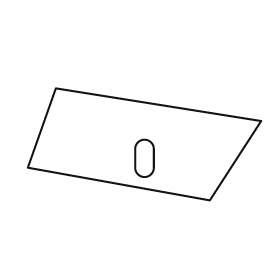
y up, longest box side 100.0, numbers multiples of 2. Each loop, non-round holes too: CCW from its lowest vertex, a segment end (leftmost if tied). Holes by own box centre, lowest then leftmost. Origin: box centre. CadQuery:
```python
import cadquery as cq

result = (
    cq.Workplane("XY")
    .moveTo(28.0, -24.0)
    .lineTo(50.0, 10.0)
    .lineTo(-38.0, 24.0)
    .lineTo(-50.0, -10.0)
    .close()
    .moveTo(-4.0, -10.0)
    .threePointArc((0.0, -14.0), (4.0, -10.0))
    .lineTo(4.0, -2.0)
    .threePointArc((0.0, 2.0), (-4.0, -2.0))
    .close()
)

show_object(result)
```